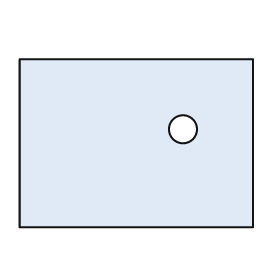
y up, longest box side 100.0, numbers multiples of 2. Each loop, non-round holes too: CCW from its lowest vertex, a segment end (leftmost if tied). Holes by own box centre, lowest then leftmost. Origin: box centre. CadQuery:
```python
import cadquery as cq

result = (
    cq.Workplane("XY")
    .moveTo(-50.0, -36.0)
    .lineTo(50.0, -36.0)
    .lineTo(50.0, 36.0)
    .lineTo(-50.0, 36.0)
    .close()
    .moveTo(20.0, 6.0)
    .circle(6.0)
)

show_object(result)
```